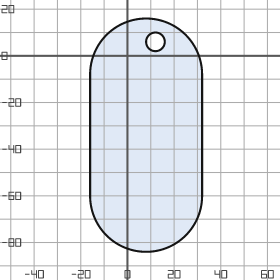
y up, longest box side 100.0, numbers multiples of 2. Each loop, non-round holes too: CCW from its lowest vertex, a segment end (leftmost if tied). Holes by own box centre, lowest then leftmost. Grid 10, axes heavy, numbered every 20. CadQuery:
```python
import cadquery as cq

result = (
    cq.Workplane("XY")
    .moveTo(-16.0, -60.0)
    .threePointArc((8.0, -84.0), (32.0, -60.0))
    .lineTo(32.0, -8.0)
    .threePointArc((8.0, 16.0), (-16.0, -8.0))
    .close()
    .moveTo(12.0, 6.0)
    .circle(4.0)
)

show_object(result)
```